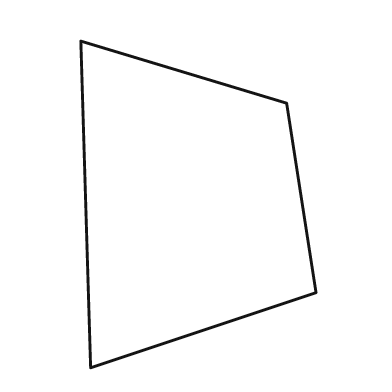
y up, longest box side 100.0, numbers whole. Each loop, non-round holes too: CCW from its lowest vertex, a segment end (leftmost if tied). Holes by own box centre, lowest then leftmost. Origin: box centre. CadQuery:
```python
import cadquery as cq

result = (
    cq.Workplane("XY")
    .moveTo(-33.0, -50.0)
    .lineTo(36.0, -27.0)
    .lineTo(27.0, 31.0)
    .lineTo(-36.0, 50.0)
    .close()
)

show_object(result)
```